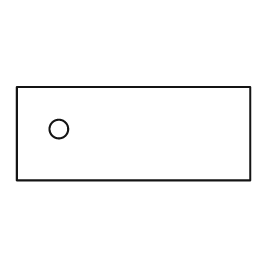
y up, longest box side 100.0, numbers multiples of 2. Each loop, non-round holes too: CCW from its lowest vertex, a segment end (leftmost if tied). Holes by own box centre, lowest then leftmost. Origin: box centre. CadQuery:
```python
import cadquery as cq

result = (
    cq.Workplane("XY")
    .moveTo(-50.0, -20.0)
    .lineTo(50.0, -20.0)
    .lineTo(50.0, 20.0)
    .lineTo(-50.0, 20.0)
    .close()
    .moveTo(-32.0, 2.0)
    .circle(4.0)
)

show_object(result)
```